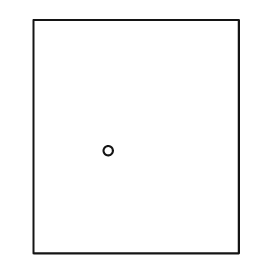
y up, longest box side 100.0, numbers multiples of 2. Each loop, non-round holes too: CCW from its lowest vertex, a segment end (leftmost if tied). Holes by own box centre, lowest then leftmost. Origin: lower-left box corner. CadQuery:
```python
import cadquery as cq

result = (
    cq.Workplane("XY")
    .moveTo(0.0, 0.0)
    .lineTo(88.0, 0.0)
    .lineTo(88.0, 100.0)
    .lineTo(0.0, 100.0)
    .close()
    .moveTo(32.0, 44.0)
    .circle(2.0)
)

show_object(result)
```